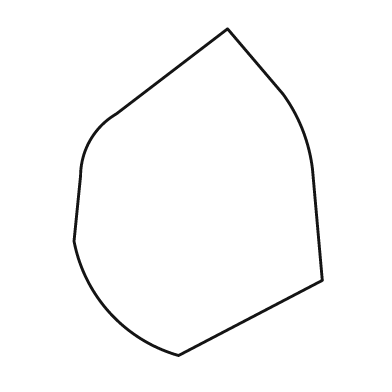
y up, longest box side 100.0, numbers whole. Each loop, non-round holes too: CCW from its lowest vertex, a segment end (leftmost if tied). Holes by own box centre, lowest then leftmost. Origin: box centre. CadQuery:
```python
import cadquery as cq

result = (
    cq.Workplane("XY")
    .moveTo(-6.0, -50.0)
    .lineTo(38.0, -27.0)
    .lineTo(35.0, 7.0)
    .threePointArc((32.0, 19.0), (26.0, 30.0))
    .lineTo(9.0, 50.0)
    .lineTo(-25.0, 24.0)
    .threePointArc((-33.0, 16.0), (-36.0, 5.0))
    .lineTo(-38.0, -15.0)
    .threePointArc((-27.0, -37.0), (-6.0, -50.0))
    .close()
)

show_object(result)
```